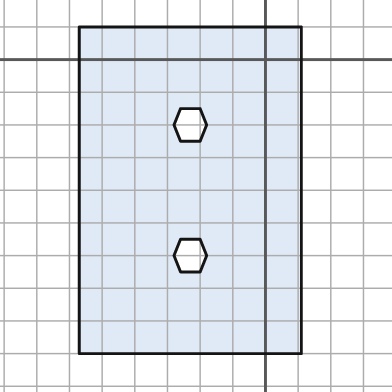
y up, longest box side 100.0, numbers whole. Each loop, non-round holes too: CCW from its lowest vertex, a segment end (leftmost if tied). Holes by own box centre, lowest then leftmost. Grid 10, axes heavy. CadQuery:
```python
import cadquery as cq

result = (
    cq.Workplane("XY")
    .moveTo(-57.0, -90.0)
    .lineTo(11.0, -90.0)
    .lineTo(11.0, 10.0)
    .lineTo(-57.0, 10.0)
    .close()
    .moveTo(-26.0, -65.0)
    .lineTo(-20.0, -65.0)
    .lineTo(-18.0, -60.0)
    .lineTo(-20.0, -55.0)
    .lineTo(-26.0, -55.0)
    .lineTo(-28.0, -60.0)
    .close()
    .moveTo(-26.0, -25.0)
    .lineTo(-20.0, -25.0)
    .lineTo(-18.0, -20.0)
    .lineTo(-20.0, -15.0)
    .lineTo(-26.0, -15.0)
    .lineTo(-28.0, -20.0)
    .close()
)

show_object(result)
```